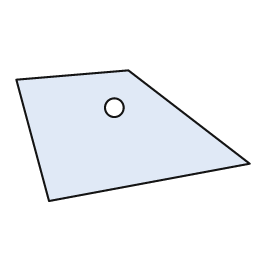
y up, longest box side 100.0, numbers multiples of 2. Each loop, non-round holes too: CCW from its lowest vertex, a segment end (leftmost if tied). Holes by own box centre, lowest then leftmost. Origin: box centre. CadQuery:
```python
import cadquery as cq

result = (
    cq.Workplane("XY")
    .moveTo(-36.0, -28.0)
    .lineTo(50.0, -12.0)
    .lineTo(-2.0, 28.0)
    .lineTo(-50.0, 24.0)
    .close()
    .moveTo(-8.0, 12.0)
    .circle(4.0)
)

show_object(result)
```